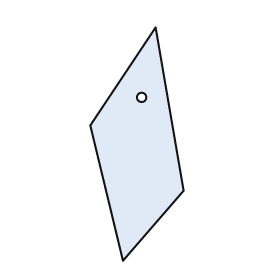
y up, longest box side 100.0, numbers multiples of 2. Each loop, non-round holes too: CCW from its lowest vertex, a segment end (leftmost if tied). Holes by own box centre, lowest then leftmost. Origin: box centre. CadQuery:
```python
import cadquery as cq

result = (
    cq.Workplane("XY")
    .moveTo(-6.0, -50.0)
    .lineTo(20.0, -20.0)
    .lineTo(8.0, 50.0)
    .lineTo(-20.0, 8.0)
    .close()
    .moveTo(2.0, 20.0)
    .circle(2.0)
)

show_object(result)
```